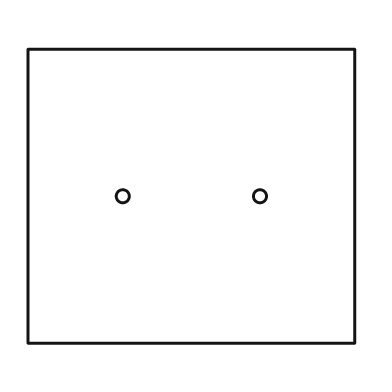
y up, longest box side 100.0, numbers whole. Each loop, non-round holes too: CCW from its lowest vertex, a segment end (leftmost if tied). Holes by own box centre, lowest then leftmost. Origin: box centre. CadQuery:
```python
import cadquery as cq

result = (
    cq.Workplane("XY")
    .moveTo(-50.0, -45.0)
    .lineTo(50.0, -45.0)
    .lineTo(50.0, 45.0)
    .lineTo(-50.0, 45.0)
    .close()
    .moveTo(-21.0, 0.0)
    .circle(2.0)
    .moveTo(21.0, 0.0)
    .circle(2.0)
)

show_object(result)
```